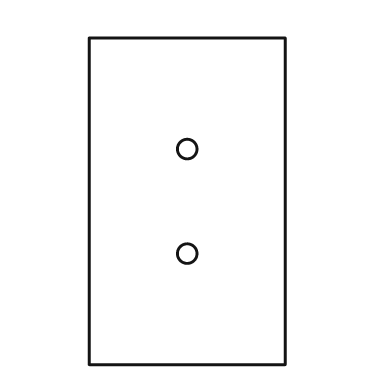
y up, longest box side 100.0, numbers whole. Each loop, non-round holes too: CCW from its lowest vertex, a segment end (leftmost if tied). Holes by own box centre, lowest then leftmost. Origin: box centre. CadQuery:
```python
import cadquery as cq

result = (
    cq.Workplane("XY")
    .moveTo(-30.0, -50.0)
    .lineTo(30.0, -50.0)
    .lineTo(30.0, 50.0)
    .lineTo(-30.0, 50.0)
    .close()
    .moveTo(0.0, -16.0)
    .circle(3.0)
    .moveTo(0.0, 16.0)
    .circle(3.0)
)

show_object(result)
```